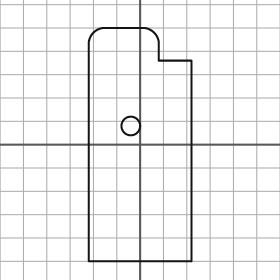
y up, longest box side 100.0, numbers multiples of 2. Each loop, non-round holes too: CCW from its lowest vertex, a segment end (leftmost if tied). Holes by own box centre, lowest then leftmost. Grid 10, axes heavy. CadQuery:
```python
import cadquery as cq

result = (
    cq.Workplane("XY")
    .moveTo(-22.0, -50.0)
    .lineTo(22.0, -50.0)
    .lineTo(22.0, 36.0)
    .lineTo(8.0, 36.0)
    .lineTo(8.0, 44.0)
    .threePointArc((6.0, 48.0), (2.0, 50.0))
    .lineTo(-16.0, 50.0)
    .threePointArc((-20.0, 48.0), (-22.0, 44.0))
    .close()
    .moveTo(-4.0, 8.0)
    .circle(4.0)
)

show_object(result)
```